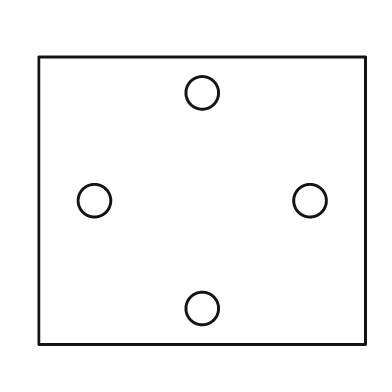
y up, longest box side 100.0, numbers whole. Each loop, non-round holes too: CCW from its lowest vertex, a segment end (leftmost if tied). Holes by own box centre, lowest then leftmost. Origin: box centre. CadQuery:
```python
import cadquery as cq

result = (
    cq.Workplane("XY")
    .moveTo(-50.0, -44.0)
    .lineTo(50.0, -44.0)
    .lineTo(50.0, 44.0)
    .lineTo(-50.0, 44.0)
    .close()
    .moveTo(0.0, -33.0)
    .circle(5.0)
    .moveTo(-33.0, 0.0)
    .circle(5.0)
    .moveTo(33.0, 0.0)
    .circle(5.0)
    .moveTo(0.0, 33.0)
    .circle(5.0)
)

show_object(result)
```